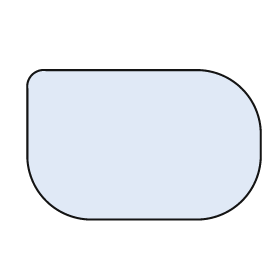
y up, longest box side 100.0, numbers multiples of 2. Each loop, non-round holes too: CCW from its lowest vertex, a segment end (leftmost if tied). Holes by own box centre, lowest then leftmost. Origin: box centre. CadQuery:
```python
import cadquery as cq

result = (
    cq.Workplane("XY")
    .moveTo(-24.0, -32.0)
    .lineTo(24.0, -32.0)
    .threePointArc((42.0, -24.0), (50.0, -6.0))
    .lineTo(50.0, 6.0)
    .threePointArc((42.0, 24.0), (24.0, 32.0))
    .lineTo(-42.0, 32.0)
    .threePointArc((-48.0, 30.0), (-50.0, 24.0))
    .lineTo(-50.0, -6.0)
    .threePointArc((-42.0, -24.0), (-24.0, -32.0))
    .close()
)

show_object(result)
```